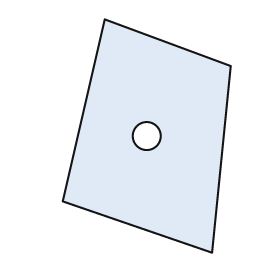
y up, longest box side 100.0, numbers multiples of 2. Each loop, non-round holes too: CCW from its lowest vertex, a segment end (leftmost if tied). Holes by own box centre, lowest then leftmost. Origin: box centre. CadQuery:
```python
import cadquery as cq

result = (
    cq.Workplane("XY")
    .moveTo(28.0, -50.0)
    .lineTo(36.0, 30.0)
    .lineTo(-18.0, 50.0)
    .lineTo(-36.0, -28.0)
    .close()
    .moveTo(0.0, 0.0)
    .circle(6.0)
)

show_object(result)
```